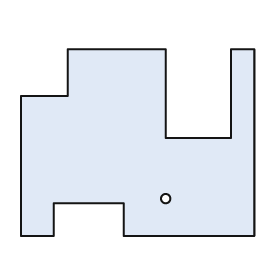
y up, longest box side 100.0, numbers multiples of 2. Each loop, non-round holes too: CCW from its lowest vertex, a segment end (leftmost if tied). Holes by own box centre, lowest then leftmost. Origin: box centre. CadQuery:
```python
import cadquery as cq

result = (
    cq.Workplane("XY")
    .moveTo(-50.0, -40.0)
    .lineTo(-36.0, -40.0)
    .lineTo(-36.0, -26.0)
    .lineTo(-6.0, -26.0)
    .lineTo(-6.0, -40.0)
    .lineTo(50.0, -40.0)
    .lineTo(50.0, 40.0)
    .lineTo(40.0, 40.0)
    .lineTo(40.0, 2.0)
    .lineTo(12.0, 2.0)
    .lineTo(12.0, 40.0)
    .lineTo(-30.0, 40.0)
    .lineTo(-30.0, 20.0)
    .lineTo(-50.0, 20.0)
    .close()
    .moveTo(12.0, -24.0)
    .circle(2.0)
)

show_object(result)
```